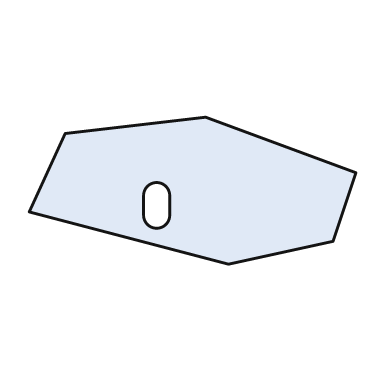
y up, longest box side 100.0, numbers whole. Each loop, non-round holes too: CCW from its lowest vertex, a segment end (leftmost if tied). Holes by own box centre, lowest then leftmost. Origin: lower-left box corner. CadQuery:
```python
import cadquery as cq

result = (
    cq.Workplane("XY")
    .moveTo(61.0, 0.0)
    .lineTo(93.0, 7.0)
    .lineTo(100.0, 28.0)
    .lineTo(54.0, 45.0)
    .lineTo(11.0, 40.0)
    .lineTo(0.0, 16.0)
    .close()
    .moveTo(35.0, 15.0)
    .threePointArc((39.0, 11.0), (43.0, 15.0))
    .lineTo(43.0, 21.0)
    .threePointArc((39.0, 25.0), (35.0, 21.0))
    .close()
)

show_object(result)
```